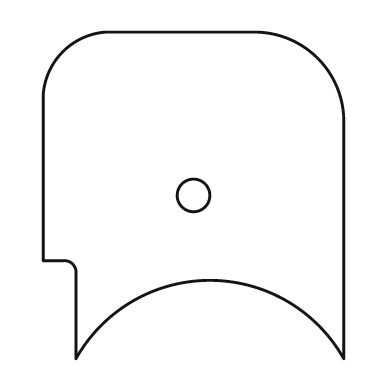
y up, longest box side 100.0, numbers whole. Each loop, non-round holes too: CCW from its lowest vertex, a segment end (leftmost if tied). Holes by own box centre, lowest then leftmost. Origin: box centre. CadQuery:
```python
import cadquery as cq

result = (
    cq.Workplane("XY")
    .moveTo(-36.0, -50.0)
    .threePointArc((5.0, -26.0), (46.0, -50.0))
    .lineTo(46.0, 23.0)
    .threePointArc((38.0, 42.0), (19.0, 50.0))
    .lineTo(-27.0, 50.0)
    .threePointArc((-40.0, 44.0), (-46.0, 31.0))
    .lineTo(-46.0, -20.0)
    .lineTo(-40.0, -20.0)
    .threePointArc((-37.0, -21.0), (-36.0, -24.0))
    .close()
    .moveTo(0.0, 0.0)
    .circle(5.0)
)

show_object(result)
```